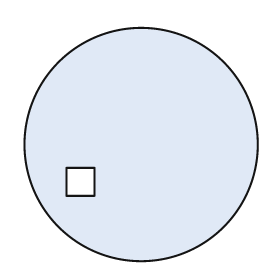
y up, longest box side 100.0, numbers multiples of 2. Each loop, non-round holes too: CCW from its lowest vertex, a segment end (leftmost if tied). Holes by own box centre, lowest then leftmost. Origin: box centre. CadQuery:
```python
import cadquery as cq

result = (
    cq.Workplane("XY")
    .moveTo(0.0, 0.0)
    .circle(50.0)
    .moveTo(-32.0, -22.0)
    .lineTo(-20.0, -22.0)
    .lineTo(-20.0, -10.0)
    .lineTo(-32.0, -10.0)
    .close()
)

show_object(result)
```